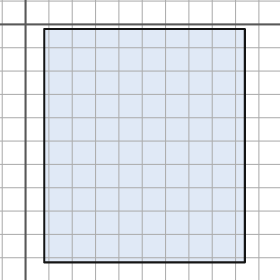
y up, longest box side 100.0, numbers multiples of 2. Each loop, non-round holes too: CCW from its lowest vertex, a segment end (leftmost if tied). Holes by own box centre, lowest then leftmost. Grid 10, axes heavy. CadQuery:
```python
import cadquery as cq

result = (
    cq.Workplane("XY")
    .moveTo(8.0, -102.0)
    .lineTo(94.0, -102.0)
    .lineTo(94.0, -2.0)
    .lineTo(8.0, -2.0)
    .close()
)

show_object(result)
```